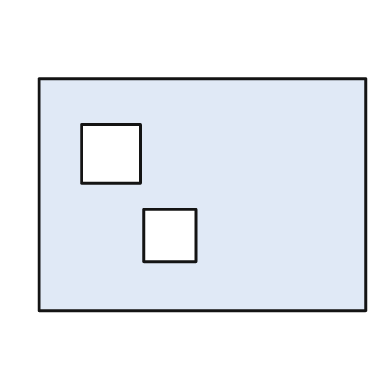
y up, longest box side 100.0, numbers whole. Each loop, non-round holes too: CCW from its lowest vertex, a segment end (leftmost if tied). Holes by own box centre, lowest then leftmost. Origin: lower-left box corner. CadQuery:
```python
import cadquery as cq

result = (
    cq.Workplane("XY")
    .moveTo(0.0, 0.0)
    .lineTo(100.0, 0.0)
    .lineTo(100.0, 71.0)
    .lineTo(0.0, 71.0)
    .close()
    .moveTo(32.0, 15.0)
    .lineTo(48.0, 15.0)
    .lineTo(48.0, 31.0)
    .lineTo(32.0, 31.0)
    .close()
    .moveTo(13.0, 39.0)
    .lineTo(31.0, 39.0)
    .lineTo(31.0, 57.0)
    .lineTo(13.0, 57.0)
    .close()
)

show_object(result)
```